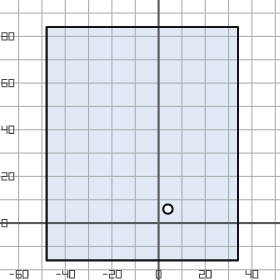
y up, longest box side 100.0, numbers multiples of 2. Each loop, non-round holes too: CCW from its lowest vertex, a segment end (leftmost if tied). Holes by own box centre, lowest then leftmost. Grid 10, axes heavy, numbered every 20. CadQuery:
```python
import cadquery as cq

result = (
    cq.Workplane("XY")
    .moveTo(-48.0, -16.0)
    .lineTo(34.0, -16.0)
    .lineTo(34.0, 84.0)
    .lineTo(-48.0, 84.0)
    .close()
    .moveTo(4.0, 6.0)
    .circle(2.0)
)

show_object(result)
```